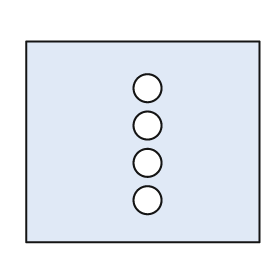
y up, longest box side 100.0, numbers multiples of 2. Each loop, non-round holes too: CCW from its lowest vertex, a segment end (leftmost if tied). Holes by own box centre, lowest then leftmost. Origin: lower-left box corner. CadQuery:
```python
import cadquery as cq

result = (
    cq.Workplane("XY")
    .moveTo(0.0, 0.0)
    .lineTo(100.0, 0.0)
    .lineTo(100.0, 86.0)
    .lineTo(0.0, 86.0)
    .close()
    .moveTo(52.0, 18.0)
    .circle(6.0)
    .moveTo(52.0, 34.0)
    .circle(6.0)
    .moveTo(52.0, 50.0)
    .circle(6.0)
    .moveTo(52.0, 66.0)
    .circle(6.0)
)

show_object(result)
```